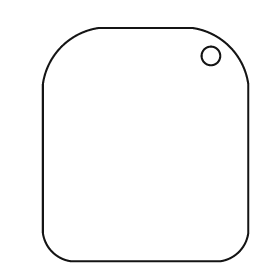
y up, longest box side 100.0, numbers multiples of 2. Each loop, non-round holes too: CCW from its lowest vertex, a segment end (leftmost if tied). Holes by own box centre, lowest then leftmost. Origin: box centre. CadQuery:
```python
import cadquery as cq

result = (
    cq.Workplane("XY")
    .moveTo(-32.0, -50.0)
    .lineTo(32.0, -50.0)
    .threePointArc((40.0, -46.0), (44.0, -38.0))
    .lineTo(44.0, 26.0)
    .threePointArc((36.0, 42.0), (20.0, 50.0))
    .lineTo(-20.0, 50.0)
    .threePointArc((-36.0, 42.0), (-44.0, 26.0))
    .lineTo(-44.0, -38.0)
    .threePointArc((-40.0, -46.0), (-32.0, -50.0))
    .close()
    .moveTo(28.0, 38.0)
    .circle(4.0)
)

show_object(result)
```